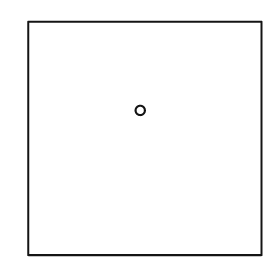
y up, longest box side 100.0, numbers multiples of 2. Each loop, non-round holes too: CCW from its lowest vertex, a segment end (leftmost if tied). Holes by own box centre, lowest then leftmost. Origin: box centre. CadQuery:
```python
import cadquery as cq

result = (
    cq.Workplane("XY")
    .moveTo(-50.0, -50.0)
    .lineTo(50.0, -50.0)
    .lineTo(50.0, 50.0)
    .lineTo(-50.0, 50.0)
    .close()
    .moveTo(-2.0, 12.0)
    .circle(2.0)
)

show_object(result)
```